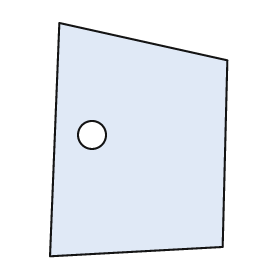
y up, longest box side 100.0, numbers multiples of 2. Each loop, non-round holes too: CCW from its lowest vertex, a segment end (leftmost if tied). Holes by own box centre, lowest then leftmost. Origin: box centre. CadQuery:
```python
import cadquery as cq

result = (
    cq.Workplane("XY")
    .moveTo(-38.0, -50.0)
    .lineTo(36.0, -46.0)
    .lineTo(38.0, 34.0)
    .lineTo(-34.0, 50.0)
    .close()
    .moveTo(-20.0, 2.0)
    .circle(6.0)
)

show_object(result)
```